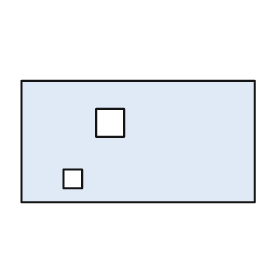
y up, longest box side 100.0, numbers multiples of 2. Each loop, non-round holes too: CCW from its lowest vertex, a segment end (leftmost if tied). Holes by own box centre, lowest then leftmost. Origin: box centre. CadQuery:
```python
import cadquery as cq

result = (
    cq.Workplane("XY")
    .moveTo(-50.0, -26.0)
    .lineTo(50.0, -26.0)
    .lineTo(50.0, 26.0)
    .lineTo(-50.0, 26.0)
    .close()
    .moveTo(-32.0, -20.0)
    .lineTo(-24.0, -20.0)
    .lineTo(-24.0, -12.0)
    .lineTo(-32.0, -12.0)
    .close()
    .moveTo(-18.0, 2.0)
    .lineTo(-6.0, 2.0)
    .lineTo(-6.0, 14.0)
    .lineTo(-18.0, 14.0)
    .close()
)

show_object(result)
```